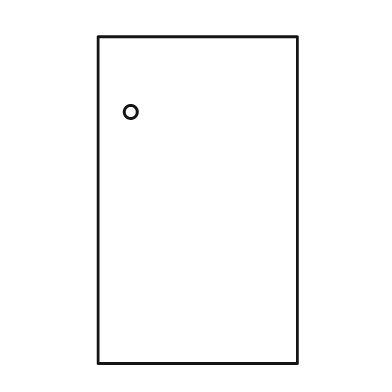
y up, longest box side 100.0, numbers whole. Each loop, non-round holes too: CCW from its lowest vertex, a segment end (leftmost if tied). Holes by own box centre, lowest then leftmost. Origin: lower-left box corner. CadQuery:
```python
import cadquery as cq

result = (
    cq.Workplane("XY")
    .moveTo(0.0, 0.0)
    .lineTo(61.0, 0.0)
    .lineTo(61.0, 100.0)
    .lineTo(0.0, 100.0)
    .close()
    .moveTo(10.0, 77.0)
    .circle(2.0)
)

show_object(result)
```